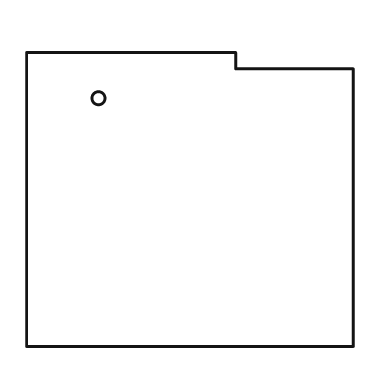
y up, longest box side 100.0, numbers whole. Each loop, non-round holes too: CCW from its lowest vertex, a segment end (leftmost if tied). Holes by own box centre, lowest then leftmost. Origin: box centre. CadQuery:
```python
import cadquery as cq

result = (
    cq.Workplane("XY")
    .moveTo(-50.0, -45.0)
    .lineTo(50.0, -45.0)
    .lineTo(50.0, 40.0)
    .lineTo(14.0, 40.0)
    .lineTo(14.0, 45.0)
    .lineTo(-50.0, 45.0)
    .close()
    .moveTo(-28.0, 31.0)
    .circle(2.0)
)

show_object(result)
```